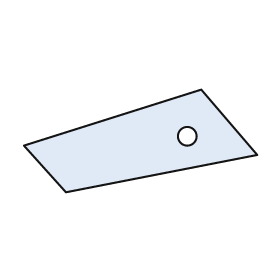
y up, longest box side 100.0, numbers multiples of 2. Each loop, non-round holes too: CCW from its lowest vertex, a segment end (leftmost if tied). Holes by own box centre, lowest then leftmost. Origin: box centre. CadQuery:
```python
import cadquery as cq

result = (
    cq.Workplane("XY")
    .moveTo(-32.0, -22.0)
    .lineTo(50.0, -6.0)
    .lineTo(26.0, 22.0)
    .lineTo(-50.0, -2.0)
    .close()
    .moveTo(20.0, 2.0)
    .circle(4.0)
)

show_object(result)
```